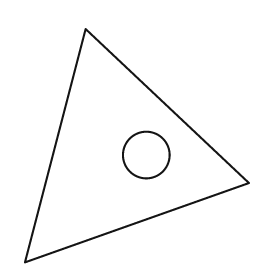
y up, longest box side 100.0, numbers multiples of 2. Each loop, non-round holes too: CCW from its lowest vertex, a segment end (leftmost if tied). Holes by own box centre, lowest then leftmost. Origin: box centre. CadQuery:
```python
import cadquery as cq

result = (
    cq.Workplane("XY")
    .moveTo(-48.0, -50.0)
    .lineTo(48.0, -16.0)
    .lineTo(-22.0, 50.0)
    .close()
    .moveTo(4.0, -4.0)
    .circle(10.0)
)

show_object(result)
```